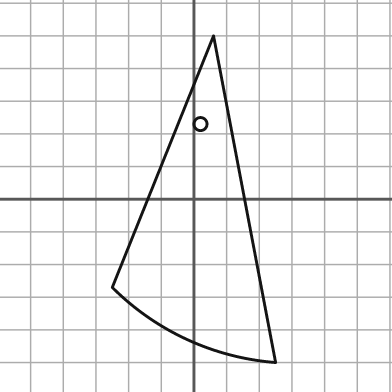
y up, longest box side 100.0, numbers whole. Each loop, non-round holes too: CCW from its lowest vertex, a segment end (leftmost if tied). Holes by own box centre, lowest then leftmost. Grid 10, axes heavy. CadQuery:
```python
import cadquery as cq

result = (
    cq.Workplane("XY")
    .moveTo(25.0, -50.0)
    .lineTo(6.0, 50.0)
    .lineTo(-25.0, -27.0)
    .threePointArc((-2.0, -43.0), (25.0, -50.0))
    .close()
    .moveTo(2.0, 23.0)
    .circle(2.0)
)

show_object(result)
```